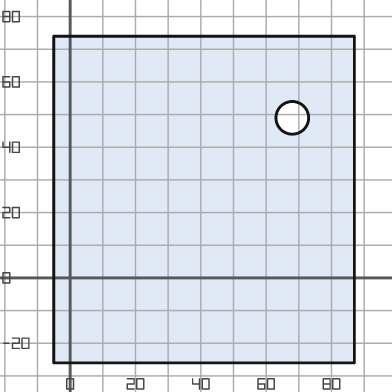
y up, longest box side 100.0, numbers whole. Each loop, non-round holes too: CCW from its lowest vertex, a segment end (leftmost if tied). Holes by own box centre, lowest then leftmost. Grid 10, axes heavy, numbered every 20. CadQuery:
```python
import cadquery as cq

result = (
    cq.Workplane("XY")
    .moveTo(-5.0, -26.0)
    .lineTo(87.0, -26.0)
    .lineTo(87.0, 74.0)
    .lineTo(-5.0, 74.0)
    .close()
    .moveTo(68.0, 49.0)
    .circle(5.0)
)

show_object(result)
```